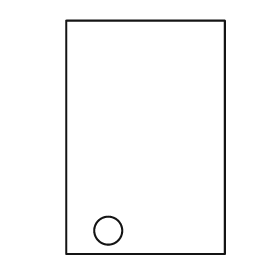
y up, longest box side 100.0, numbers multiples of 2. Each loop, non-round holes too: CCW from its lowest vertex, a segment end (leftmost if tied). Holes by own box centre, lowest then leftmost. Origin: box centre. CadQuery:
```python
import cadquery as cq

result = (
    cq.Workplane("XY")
    .moveTo(-34.0, -50.0)
    .lineTo(34.0, -50.0)
    .lineTo(34.0, 50.0)
    .lineTo(-34.0, 50.0)
    .close()
    .moveTo(-16.0, -40.0)
    .circle(6.0)
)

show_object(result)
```